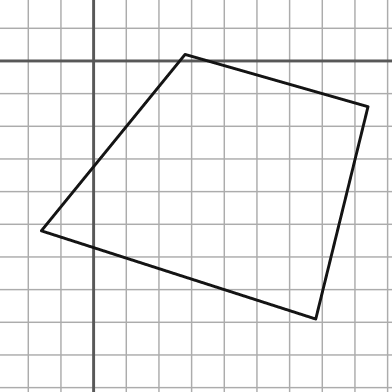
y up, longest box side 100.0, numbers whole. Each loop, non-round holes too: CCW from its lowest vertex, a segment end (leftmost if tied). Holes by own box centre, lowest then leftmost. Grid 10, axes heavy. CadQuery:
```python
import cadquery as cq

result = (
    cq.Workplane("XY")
    .moveTo(68.0, -79.0)
    .lineTo(84.0, -14.0)
    .lineTo(28.0, 2.0)
    .lineTo(-16.0, -52.0)
    .close()
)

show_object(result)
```